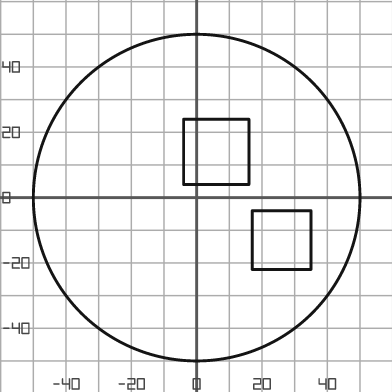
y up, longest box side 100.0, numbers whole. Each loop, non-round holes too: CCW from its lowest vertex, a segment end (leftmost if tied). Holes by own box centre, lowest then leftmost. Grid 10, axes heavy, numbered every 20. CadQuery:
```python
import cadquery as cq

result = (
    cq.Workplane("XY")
    .moveTo(0.0, 0.0)
    .circle(50.0)
    .moveTo(17.0, -22.0)
    .lineTo(35.0, -22.0)
    .lineTo(35.0, -4.0)
    .lineTo(17.0, -4.0)
    .close()
    .moveTo(-4.0, 4.0)
    .lineTo(16.0, 4.0)
    .lineTo(16.0, 24.0)
    .lineTo(-4.0, 24.0)
    .close()
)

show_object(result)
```